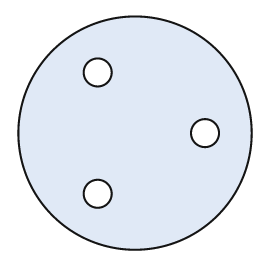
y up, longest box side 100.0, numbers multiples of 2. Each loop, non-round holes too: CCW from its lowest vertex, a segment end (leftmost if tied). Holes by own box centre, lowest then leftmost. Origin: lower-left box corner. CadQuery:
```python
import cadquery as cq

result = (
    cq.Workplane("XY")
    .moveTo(50.0, 50.0)
    .circle(50.0)
    .moveTo(34.0, 24.0)
    .circle(6.0)
    .moveTo(80.0, 50.0)
    .circle(6.0)
    .moveTo(34.0, 76.0)
    .circle(6.0)
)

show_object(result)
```